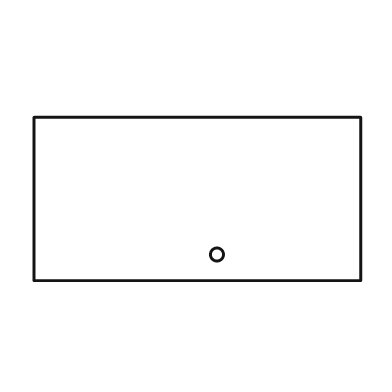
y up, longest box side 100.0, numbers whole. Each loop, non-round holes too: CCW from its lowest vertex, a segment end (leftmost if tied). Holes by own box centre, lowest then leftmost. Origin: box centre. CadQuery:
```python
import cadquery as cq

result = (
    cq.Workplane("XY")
    .moveTo(-50.0, -25.0)
    .lineTo(50.0, -25.0)
    .lineTo(50.0, 25.0)
    .lineTo(-50.0, 25.0)
    .close()
    .moveTo(6.0, -17.0)
    .circle(2.0)
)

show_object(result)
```